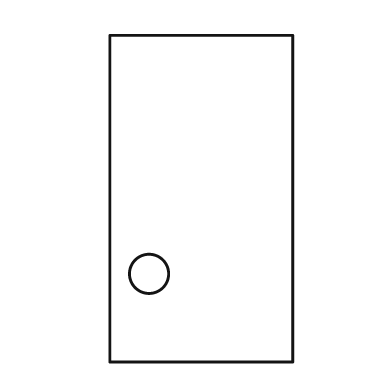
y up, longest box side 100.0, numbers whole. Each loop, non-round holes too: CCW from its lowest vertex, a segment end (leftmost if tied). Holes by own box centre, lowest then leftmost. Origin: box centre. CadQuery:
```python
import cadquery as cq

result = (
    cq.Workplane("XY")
    .moveTo(-28.0, -50.0)
    .lineTo(28.0, -50.0)
    .lineTo(28.0, 50.0)
    .lineTo(-28.0, 50.0)
    .close()
    .moveTo(-16.0, -23.0)
    .circle(6.0)
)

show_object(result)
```